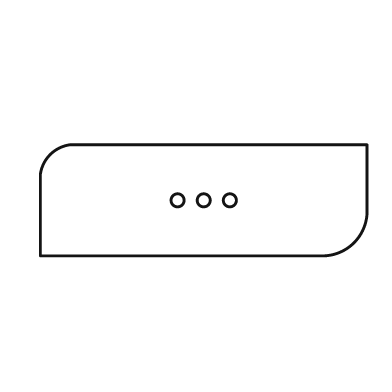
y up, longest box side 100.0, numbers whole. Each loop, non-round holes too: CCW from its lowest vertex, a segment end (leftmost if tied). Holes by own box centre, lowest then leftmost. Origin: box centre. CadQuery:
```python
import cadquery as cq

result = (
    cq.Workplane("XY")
    .moveTo(-50.0, -17.0)
    .lineTo(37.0, -17.0)
    .threePointArc((46.0, -13.0), (50.0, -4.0))
    .lineTo(50.0, 17.0)
    .lineTo(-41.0, 17.0)
    .threePointArc((-47.0, 14.0), (-50.0, 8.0))
    .close()
    .moveTo(-8.0, 0.0)
    .circle(2.0)
    .moveTo(0.0, 0.0)
    .circle(2.0)
    .moveTo(8.0, 0.0)
    .circle(2.0)
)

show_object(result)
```